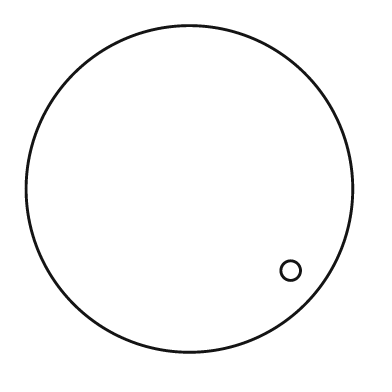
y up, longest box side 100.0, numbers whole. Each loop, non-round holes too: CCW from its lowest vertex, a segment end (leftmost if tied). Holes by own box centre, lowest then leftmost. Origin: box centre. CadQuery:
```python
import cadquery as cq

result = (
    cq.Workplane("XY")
    .moveTo(0.0, 0.0)
    .circle(50.0)
    .moveTo(31.0, -25.0)
    .circle(3.0)
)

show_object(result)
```